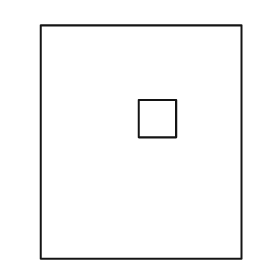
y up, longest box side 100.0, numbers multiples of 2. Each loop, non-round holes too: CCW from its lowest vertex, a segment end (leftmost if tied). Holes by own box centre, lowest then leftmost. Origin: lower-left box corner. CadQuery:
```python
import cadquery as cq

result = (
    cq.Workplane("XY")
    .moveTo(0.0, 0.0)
    .lineTo(86.0, 0.0)
    .lineTo(86.0, 100.0)
    .lineTo(0.0, 100.0)
    .close()
    .moveTo(42.0, 52.0)
    .lineTo(58.0, 52.0)
    .lineTo(58.0, 68.0)
    .lineTo(42.0, 68.0)
    .close()
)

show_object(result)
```